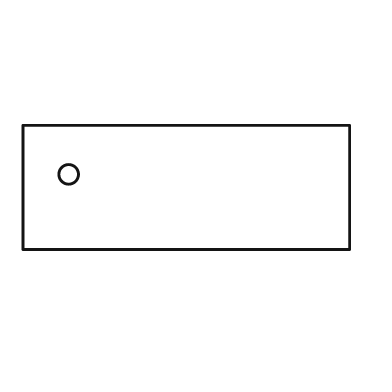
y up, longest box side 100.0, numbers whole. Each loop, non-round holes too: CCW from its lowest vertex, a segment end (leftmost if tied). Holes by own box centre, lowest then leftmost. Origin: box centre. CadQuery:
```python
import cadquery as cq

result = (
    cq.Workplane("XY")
    .moveTo(-50.0, -19.0)
    .lineTo(50.0, -19.0)
    .lineTo(50.0, 19.0)
    .lineTo(-50.0, 19.0)
    .close()
    .moveTo(-36.0, 4.0)
    .circle(3.0)
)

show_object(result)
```